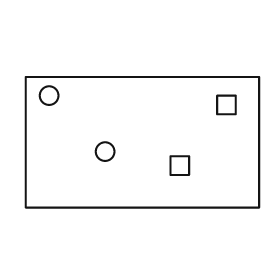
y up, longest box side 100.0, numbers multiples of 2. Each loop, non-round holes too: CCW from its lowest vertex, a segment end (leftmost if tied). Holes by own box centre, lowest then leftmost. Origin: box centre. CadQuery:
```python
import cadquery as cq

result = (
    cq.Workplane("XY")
    .moveTo(-50.0, -28.0)
    .lineTo(50.0, -28.0)
    .lineTo(50.0, 28.0)
    .lineTo(-50.0, 28.0)
    .close()
    .moveTo(12.0, -14.0)
    .lineTo(20.0, -14.0)
    .lineTo(20.0, -6.0)
    .lineTo(12.0, -6.0)
    .close()
    .moveTo(-16.0, -4.0)
    .circle(4.0)
    .moveTo(32.0, 12.0)
    .lineTo(40.0, 12.0)
    .lineTo(40.0, 20.0)
    .lineTo(32.0, 20.0)
    .close()
    .moveTo(-40.0, 20.0)
    .circle(4.0)
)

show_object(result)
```